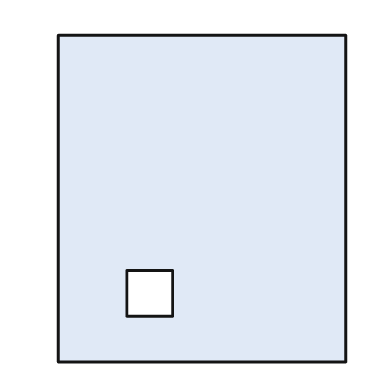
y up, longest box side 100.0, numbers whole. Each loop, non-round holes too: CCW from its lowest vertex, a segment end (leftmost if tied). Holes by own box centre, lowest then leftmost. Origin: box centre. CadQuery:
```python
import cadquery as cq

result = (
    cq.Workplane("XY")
    .moveTo(-44.0, -50.0)
    .lineTo(44.0, -50.0)
    .lineTo(44.0, 50.0)
    .lineTo(-44.0, 50.0)
    .close()
    .moveTo(-23.0, -36.0)
    .lineTo(-9.0, -36.0)
    .lineTo(-9.0, -22.0)
    .lineTo(-23.0, -22.0)
    .close()
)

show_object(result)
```